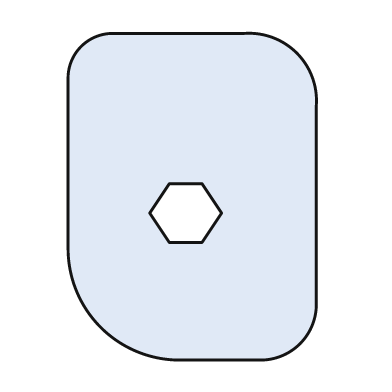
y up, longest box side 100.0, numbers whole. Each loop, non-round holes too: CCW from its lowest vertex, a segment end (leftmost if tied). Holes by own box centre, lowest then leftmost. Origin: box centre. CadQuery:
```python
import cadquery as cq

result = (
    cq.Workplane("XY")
    .moveTo(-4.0, -50.0)
    .lineTo(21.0, -50.0)
    .threePointArc((33.0, -45.0), (38.0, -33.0))
    .lineTo(38.0, 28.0)
    .threePointArc((32.0, 44.0), (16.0, 50.0))
    .lineTo(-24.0, 50.0)
    .threePointArc((-34.0, 46.0), (-38.0, 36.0))
    .lineTo(-38.0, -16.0)
    .threePointArc((-28.0, -40.0), (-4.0, -50.0))
    .close()
    .moveTo(-7.0, -14.0)
    .lineTo(3.0, -14.0)
    .lineTo(9.0, -5.0)
    .lineTo(3.0, 4.0)
    .lineTo(-7.0, 4.0)
    .lineTo(-13.0, -5.0)
    .close()
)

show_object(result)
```